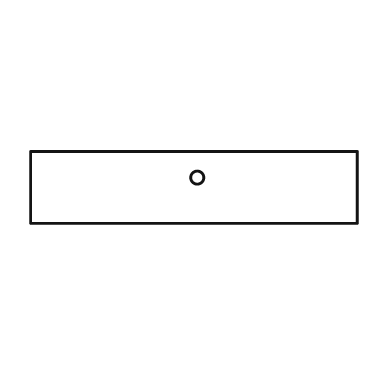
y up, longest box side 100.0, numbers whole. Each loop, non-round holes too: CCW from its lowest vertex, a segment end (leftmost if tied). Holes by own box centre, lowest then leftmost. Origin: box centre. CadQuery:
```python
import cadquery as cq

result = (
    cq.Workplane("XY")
    .moveTo(-50.0, -11.0)
    .lineTo(50.0, -11.0)
    .lineTo(50.0, 11.0)
    .lineTo(-50.0, 11.0)
    .close()
    .moveTo(1.0, 3.0)
    .circle(2.0)
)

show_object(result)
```